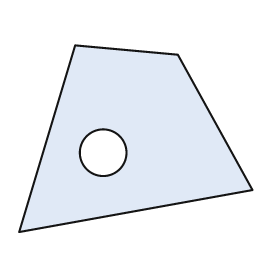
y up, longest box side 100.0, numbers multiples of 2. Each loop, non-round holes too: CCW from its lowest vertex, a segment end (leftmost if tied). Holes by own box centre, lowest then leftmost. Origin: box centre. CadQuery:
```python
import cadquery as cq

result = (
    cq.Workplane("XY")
    .moveTo(-50.0, -40.0)
    .lineTo(50.0, -22.0)
    .lineTo(18.0, 36.0)
    .lineTo(-26.0, 40.0)
    .close()
    .moveTo(-14.0, -6.0)
    .circle(10.0)
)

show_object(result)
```